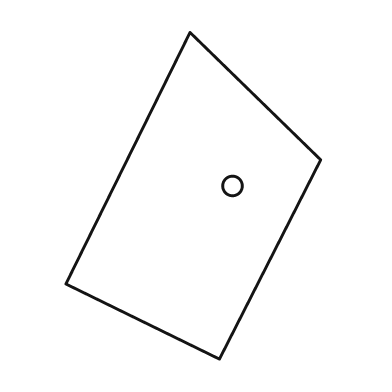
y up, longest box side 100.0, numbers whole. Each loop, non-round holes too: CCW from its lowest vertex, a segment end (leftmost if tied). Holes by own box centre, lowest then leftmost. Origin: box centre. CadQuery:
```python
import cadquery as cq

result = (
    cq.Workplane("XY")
    .moveTo(8.0, -50.0)
    .lineTo(39.0, 11.0)
    .lineTo(-1.0, 50.0)
    .lineTo(-39.0, -27.0)
    .close()
    .moveTo(12.0, 3.0)
    .circle(3.0)
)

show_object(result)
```